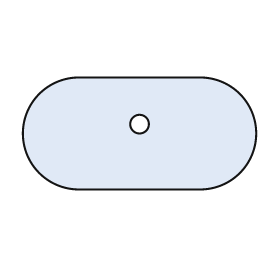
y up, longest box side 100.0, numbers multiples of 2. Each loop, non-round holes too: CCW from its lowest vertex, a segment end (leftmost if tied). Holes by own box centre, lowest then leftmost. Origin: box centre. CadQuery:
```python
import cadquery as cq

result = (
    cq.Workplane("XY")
    .moveTo(-26.0, -24.0)
    .lineTo(26.0, -24.0)
    .threePointArc((50.0, 0.0), (26.0, 24.0))
    .lineTo(-26.0, 24.0)
    .threePointArc((-50.0, 0.0), (-26.0, -24.0))
    .close()
    .moveTo(0.0, 4.0)
    .circle(4.0)
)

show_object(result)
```